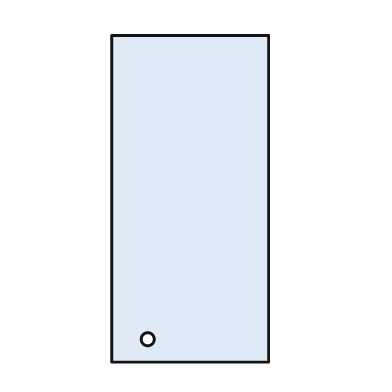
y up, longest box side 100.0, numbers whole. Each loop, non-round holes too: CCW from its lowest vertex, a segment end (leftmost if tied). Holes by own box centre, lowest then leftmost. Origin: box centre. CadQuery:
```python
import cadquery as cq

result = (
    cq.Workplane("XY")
    .moveTo(-24.0, -50.0)
    .lineTo(24.0, -50.0)
    .lineTo(24.0, 50.0)
    .lineTo(-24.0, 50.0)
    .close()
    .moveTo(-13.0, -43.0)
    .circle(2.0)
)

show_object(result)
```